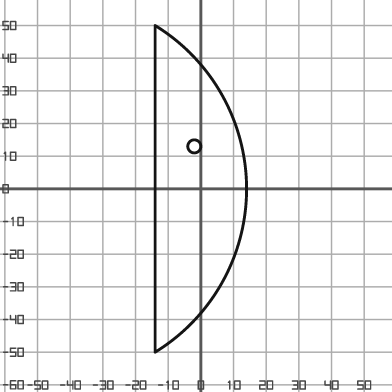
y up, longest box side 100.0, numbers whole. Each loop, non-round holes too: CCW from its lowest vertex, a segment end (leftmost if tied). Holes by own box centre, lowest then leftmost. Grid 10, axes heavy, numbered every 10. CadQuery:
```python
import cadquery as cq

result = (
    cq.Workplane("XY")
    .moveTo(-14.0, -50.0)
    .threePointArc((14.0, 0.0), (-14.0, 50.0))
    .close()
    .moveTo(-2.0, 13.0)
    .circle(2.0)
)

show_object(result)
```